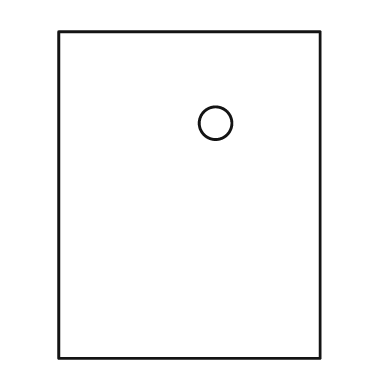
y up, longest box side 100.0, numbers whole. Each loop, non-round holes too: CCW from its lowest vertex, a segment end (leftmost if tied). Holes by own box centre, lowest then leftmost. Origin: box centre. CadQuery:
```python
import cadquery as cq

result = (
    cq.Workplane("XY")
    .moveTo(-40.0, -50.0)
    .lineTo(40.0, -50.0)
    .lineTo(40.0, 50.0)
    .lineTo(-40.0, 50.0)
    .close()
    .moveTo(8.0, 22.0)
    .circle(5.0)
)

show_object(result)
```